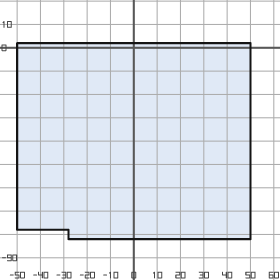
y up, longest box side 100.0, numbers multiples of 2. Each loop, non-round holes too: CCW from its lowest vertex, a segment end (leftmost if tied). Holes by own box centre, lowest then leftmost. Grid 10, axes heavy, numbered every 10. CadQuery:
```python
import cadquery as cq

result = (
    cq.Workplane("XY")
    .moveTo(-28.0, -82.0)
    .lineTo(50.0, -82.0)
    .lineTo(50.0, 2.0)
    .lineTo(-50.0, 2.0)
    .lineTo(-50.0, -78.0)
    .lineTo(-28.0, -78.0)
    .close()
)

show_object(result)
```